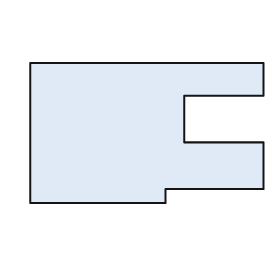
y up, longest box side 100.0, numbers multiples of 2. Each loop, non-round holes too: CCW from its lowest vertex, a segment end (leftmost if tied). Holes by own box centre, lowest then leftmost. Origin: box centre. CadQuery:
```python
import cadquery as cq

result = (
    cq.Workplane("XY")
    .moveTo(-50.0, -30.0)
    .lineTo(8.0, -30.0)
    .lineTo(8.0, -24.0)
    .lineTo(50.0, -24.0)
    .lineTo(50.0, -4.0)
    .lineTo(16.0, -4.0)
    .lineTo(16.0, 16.0)
    .lineTo(50.0, 16.0)
    .lineTo(50.0, 30.0)
    .lineTo(-50.0, 30.0)
    .close()
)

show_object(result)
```